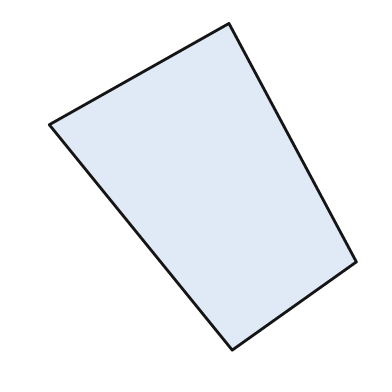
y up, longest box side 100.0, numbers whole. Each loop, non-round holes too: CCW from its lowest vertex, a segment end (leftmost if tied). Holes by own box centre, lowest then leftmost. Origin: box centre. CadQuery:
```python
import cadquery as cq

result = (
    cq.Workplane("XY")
    .moveTo(9.0, -50.0)
    .lineTo(47.0, -23.0)
    .lineTo(8.0, 50.0)
    .lineTo(-47.0, 19.0)
    .close()
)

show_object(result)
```